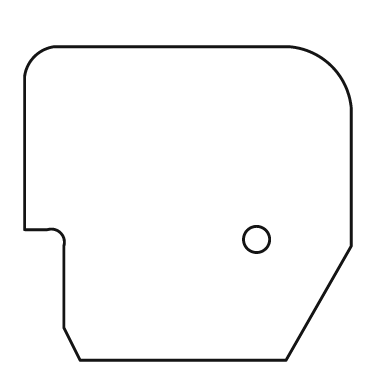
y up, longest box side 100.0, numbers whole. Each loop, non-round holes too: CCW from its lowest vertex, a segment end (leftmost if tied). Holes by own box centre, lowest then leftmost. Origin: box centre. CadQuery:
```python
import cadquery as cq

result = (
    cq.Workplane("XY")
    .moveTo(-33.0, -48.0)
    .lineTo(30.0, -48.0)
    .lineTo(50.0, -13.0)
    .lineTo(50.0, 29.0)
    .threePointArc((44.0, 42.0), (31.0, 48.0))
    .lineTo(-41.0, 48.0)
    .threePointArc((-47.0, 45.0), (-50.0, 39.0))
    .lineTo(-50.0, -8.0)
    .lineTo(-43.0, -8.0)
    .threePointArc((-39.0, -9.0), (-38.0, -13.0))
    .lineTo(-38.0, -38.0)
    .close()
    .moveTo(21.0, -11.0)
    .circle(4.0)
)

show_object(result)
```